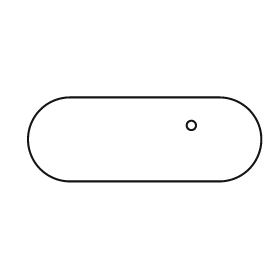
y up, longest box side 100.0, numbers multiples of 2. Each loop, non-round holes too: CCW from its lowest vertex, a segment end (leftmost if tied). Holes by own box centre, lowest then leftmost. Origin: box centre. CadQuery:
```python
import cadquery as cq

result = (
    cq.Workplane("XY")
    .moveTo(-32.0, -18.0)
    .lineTo(32.0, -18.0)
    .threePointArc((50.0, 0.0), (32.0, 18.0))
    .lineTo(-32.0, 18.0)
    .threePointArc((-50.0, 0.0), (-32.0, -18.0))
    .close()
    .moveTo(20.0, 6.0)
    .circle(2.0)
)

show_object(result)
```